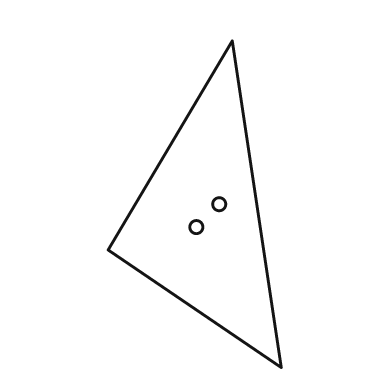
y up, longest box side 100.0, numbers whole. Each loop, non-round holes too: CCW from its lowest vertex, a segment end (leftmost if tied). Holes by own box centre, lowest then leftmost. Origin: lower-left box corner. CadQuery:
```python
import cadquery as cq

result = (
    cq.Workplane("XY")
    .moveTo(53.0, 0.0)
    .lineTo(38.0, 100.0)
    .lineTo(0.0, 36.0)
    .close()
    .moveTo(27.0, 43.0)
    .circle(2.0)
    .moveTo(34.0, 50.0)
    .circle(2.0)
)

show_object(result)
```